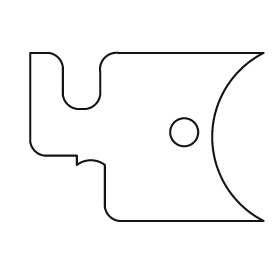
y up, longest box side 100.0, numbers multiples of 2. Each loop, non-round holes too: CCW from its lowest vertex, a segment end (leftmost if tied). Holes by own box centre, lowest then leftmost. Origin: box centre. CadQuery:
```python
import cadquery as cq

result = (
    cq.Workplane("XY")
    .moveTo(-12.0, -36.0)
    .lineTo(50.0, -36.0)
    .threePointArc((28.0, 0.0), (50.0, 36.0))
    .lineTo(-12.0, 36.0)
    .threePointArc((-18.0, 34.0), (-20.0, 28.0))
    .lineTo(-20.0, 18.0)
    .threePointArc((-22.0, 14.0), (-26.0, 12.0))
    .lineTo(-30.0, 12.0)
    .threePointArc((-34.0, 14.0), (-36.0, 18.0))
    .lineTo(-36.0, 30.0)
    .threePointArc((-38.0, 34.0), (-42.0, 36.0))
    .lineTo(-50.0, 36.0)
    .lineTo(-50.0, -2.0)
    .threePointArc((-48.0, -6.0), (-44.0, -8.0))
    .lineTo(-30.0, -8.0)
    .lineTo(-30.0, -12.0)
    .threePointArc((-24.0, -10.0), (-18.0, -12.0))
    .lineTo(-18.0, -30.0)
    .threePointArc((-16.0, -34.0), (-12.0, -36.0))
    .close()
    .moveTo(16.0, 2.0)
    .circle(6.0)
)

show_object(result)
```